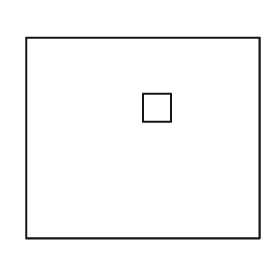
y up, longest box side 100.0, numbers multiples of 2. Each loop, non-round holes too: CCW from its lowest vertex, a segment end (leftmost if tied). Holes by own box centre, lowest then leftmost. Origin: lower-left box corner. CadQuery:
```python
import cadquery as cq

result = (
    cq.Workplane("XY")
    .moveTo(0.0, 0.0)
    .lineTo(100.0, 0.0)
    .lineTo(100.0, 86.0)
    .lineTo(0.0, 86.0)
    .close()
    .moveTo(50.0, 50.0)
    .lineTo(62.0, 50.0)
    .lineTo(62.0, 62.0)
    .lineTo(50.0, 62.0)
    .close()
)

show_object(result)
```